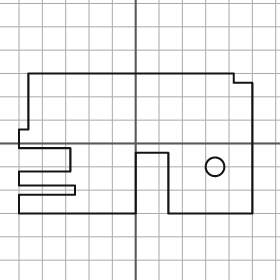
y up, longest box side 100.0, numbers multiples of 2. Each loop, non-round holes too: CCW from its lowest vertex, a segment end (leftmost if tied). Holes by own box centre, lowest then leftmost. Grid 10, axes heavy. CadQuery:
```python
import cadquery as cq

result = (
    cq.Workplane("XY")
    .moveTo(-50.0, -30.0)
    .lineTo(0.0, -30.0)
    .lineTo(0.0, -4.0)
    .lineTo(14.0, -4.0)
    .lineTo(14.0, -30.0)
    .lineTo(50.0, -30.0)
    .lineTo(50.0, 26.0)
    .lineTo(42.0, 26.0)
    .lineTo(42.0, 30.0)
    .lineTo(-46.0, 30.0)
    .lineTo(-46.0, 6.0)
    .lineTo(-50.0, 6.0)
    .lineTo(-50.0, -2.0)
    .lineTo(-28.0, -2.0)
    .lineTo(-28.0, -12.0)
    .lineTo(-50.0, -12.0)
    .lineTo(-50.0, -18.0)
    .lineTo(-26.0, -18.0)
    .lineTo(-26.0, -22.0)
    .lineTo(-50.0, -22.0)
    .close()
    .moveTo(34.0, -10.0)
    .circle(4.0)
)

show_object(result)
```